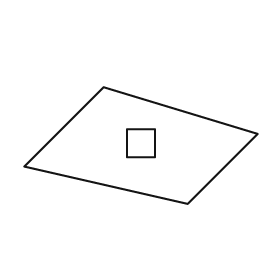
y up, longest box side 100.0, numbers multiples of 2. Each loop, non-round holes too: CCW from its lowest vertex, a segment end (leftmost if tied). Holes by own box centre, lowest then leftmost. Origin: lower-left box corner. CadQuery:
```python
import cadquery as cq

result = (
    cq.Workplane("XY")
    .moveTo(70.0, 0.0)
    .lineTo(100.0, 30.0)
    .lineTo(34.0, 50.0)
    .lineTo(0.0, 16.0)
    .close()
    .moveTo(44.0, 20.0)
    .lineTo(56.0, 20.0)
    .lineTo(56.0, 32.0)
    .lineTo(44.0, 32.0)
    .close()
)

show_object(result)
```